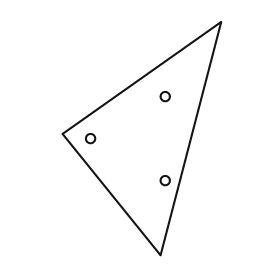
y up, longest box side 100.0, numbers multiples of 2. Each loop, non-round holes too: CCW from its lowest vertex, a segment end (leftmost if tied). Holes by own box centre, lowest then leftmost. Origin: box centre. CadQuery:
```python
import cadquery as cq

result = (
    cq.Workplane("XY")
    .moveTo(8.0, -50.0)
    .lineTo(34.0, 50.0)
    .lineTo(-34.0, 2.0)
    .close()
    .moveTo(10.0, -18.0)
    .circle(2.0)
    .moveTo(-22.0, 0.0)
    .circle(2.0)
    .moveTo(10.0, 18.0)
    .circle(2.0)
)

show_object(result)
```